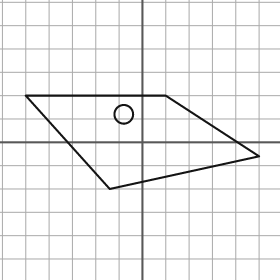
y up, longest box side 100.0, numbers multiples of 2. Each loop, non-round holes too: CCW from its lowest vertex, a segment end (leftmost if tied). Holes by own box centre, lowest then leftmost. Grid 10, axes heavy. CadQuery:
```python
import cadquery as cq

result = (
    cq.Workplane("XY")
    .moveTo(-14.0, -20.0)
    .lineTo(50.0, -6.0)
    .lineTo(10.0, 20.0)
    .lineTo(-50.0, 20.0)
    .close()
    .moveTo(-8.0, 12.0)
    .circle(4.0)
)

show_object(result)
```